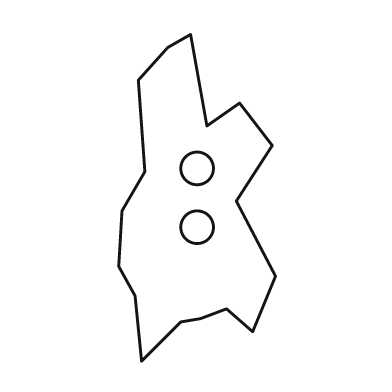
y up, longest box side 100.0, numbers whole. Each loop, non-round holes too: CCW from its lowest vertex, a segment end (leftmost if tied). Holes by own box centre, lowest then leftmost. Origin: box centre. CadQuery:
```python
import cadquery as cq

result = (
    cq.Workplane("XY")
    .moveTo(-17.0, -50.0)
    .lineTo(-5.0, -38.0)
    .lineTo(1.0, -37.0)
    .lineTo(9.0, -34.0)
    .lineTo(17.0, -41.0)
    .lineTo(24.0, -24.0)
    .lineTo(12.0, -1.0)
    .lineTo(23.0, 16.0)
    .lineTo(13.0, 29.0)
    .lineTo(3.0, 22.0)
    .lineTo(-2.0, 50.0)
    .lineTo(-9.0, 46.0)
    .lineTo(-18.0, 36.0)
    .lineTo(-16.0, 8.0)
    .lineTo(-23.0, -4.0)
    .lineTo(-24.0, -21.0)
    .lineTo(-19.0, -30.0)
    .close()
    .moveTo(0.0, -9.0)
    .circle(5.0)
    .moveTo(0.0, 9.0)
    .circle(5.0)
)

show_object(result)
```